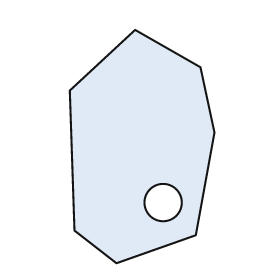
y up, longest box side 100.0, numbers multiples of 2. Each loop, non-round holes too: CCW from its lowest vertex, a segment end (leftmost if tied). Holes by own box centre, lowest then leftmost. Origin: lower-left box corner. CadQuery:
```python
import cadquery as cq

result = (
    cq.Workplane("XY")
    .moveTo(20.0, 0.0)
    .lineTo(54.0, 12.0)
    .lineTo(62.0, 56.0)
    .lineTo(56.0, 84.0)
    .lineTo(28.0, 100.0)
    .lineTo(0.0, 74.0)
    .lineTo(2.0, 14.0)
    .close()
    .moveTo(40.0, 26.0)
    .circle(8.0)
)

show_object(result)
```